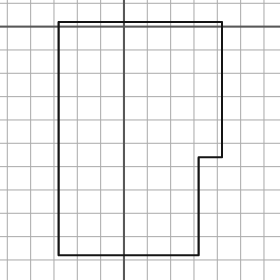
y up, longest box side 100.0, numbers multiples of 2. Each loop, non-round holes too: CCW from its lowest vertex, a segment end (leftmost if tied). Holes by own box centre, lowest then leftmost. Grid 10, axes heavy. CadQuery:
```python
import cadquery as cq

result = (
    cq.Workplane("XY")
    .moveTo(-28.0, -98.0)
    .lineTo(32.0, -98.0)
    .lineTo(32.0, -56.0)
    .lineTo(42.0, -56.0)
    .lineTo(42.0, 2.0)
    .lineTo(-28.0, 2.0)
    .close()
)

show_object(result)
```